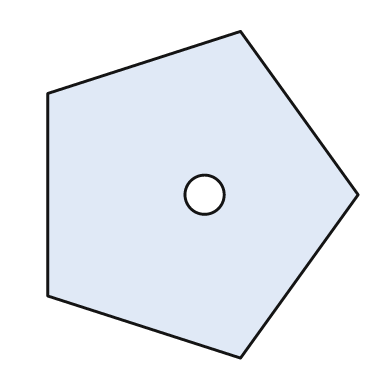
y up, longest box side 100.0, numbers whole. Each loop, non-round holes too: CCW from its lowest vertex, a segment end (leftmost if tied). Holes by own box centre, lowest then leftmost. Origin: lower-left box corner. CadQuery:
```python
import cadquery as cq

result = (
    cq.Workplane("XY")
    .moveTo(59.0, 0.0)
    .lineTo(95.0, 50.0)
    .lineTo(59.0, 100.0)
    .lineTo(0.0, 81.0)
    .lineTo(0.0, 19.0)
    .close()
    .moveTo(48.0, 50.0)
    .circle(6.0)
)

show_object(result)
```